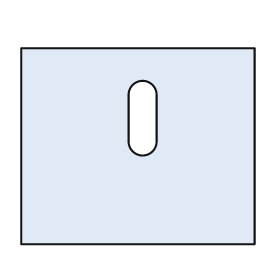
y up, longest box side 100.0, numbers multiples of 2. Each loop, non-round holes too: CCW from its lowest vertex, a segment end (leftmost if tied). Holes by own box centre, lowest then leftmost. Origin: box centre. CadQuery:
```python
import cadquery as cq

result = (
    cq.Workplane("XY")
    .moveTo(-50.0, -42.0)
    .lineTo(50.0, -42.0)
    .lineTo(50.0, 42.0)
    .lineTo(-50.0, 42.0)
    .close()
    .moveTo(-4.0, 2.0)
    .threePointArc((2.0, -4.0), (8.0, 2.0))
    .lineTo(8.0, 22.0)
    .threePointArc((2.0, 28.0), (-4.0, 22.0))
    .close()
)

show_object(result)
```